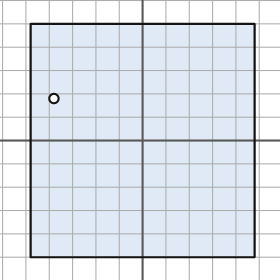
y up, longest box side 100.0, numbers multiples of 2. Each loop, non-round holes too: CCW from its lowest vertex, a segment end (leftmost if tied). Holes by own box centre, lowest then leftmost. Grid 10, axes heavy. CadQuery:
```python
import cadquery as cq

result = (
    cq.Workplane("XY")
    .moveTo(-48.0, -50.0)
    .lineTo(48.0, -50.0)
    .lineTo(48.0, 50.0)
    .lineTo(-48.0, 50.0)
    .close()
    .moveTo(-38.0, 18.0)
    .circle(2.0)
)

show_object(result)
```